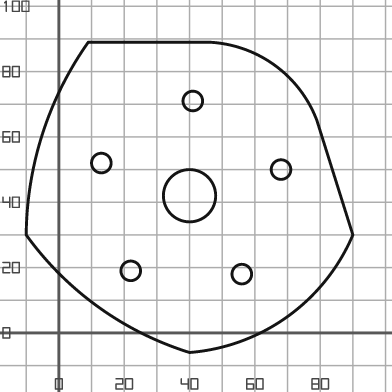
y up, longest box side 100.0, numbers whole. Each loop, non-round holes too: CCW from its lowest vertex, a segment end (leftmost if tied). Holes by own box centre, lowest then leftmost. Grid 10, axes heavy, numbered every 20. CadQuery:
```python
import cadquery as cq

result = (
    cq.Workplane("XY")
    .moveTo(40.0, -6.0)
    .threePointArc((70.0, 5.0), (90.0, 30.0))
    .lineTo(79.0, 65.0)
    .threePointArc((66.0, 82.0), (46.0, 89.0))
    .lineTo(9.0, 89.0)
    .threePointArc((-5.0, 61.0), (-10.0, 30.0))
    .threePointArc((12.0, 8.0), (40.0, -6.0))
    .close()
    .moveTo(56.0, 18.0)
    .circle(3.0)
    .moveTo(22.0, 19.0)
    .circle(3.0)
    .moveTo(40.0, 42.0)
    .circle(8.0)
    .moveTo(68.0, 50.0)
    .circle(3.0)
    .moveTo(13.0, 52.0)
    .circle(3.0)
    .moveTo(41.0, 71.0)
    .circle(3.0)
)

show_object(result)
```